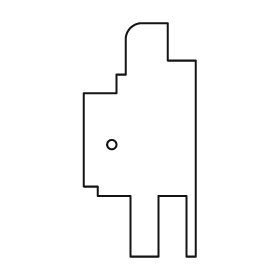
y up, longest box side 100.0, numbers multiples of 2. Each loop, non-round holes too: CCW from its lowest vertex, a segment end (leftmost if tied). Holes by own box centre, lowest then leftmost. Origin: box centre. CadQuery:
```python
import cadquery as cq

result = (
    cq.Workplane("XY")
    .moveTo(-4.0, -50.0)
    .lineTo(8.0, -50.0)
    .lineTo(8.0, -24.0)
    .lineTo(20.0, -24.0)
    .lineTo(20.0, -50.0)
    .lineTo(24.0, -50.0)
    .lineTo(24.0, 34.0)
    .lineTo(12.0, 34.0)
    .lineTo(12.0, 50.0)
    .lineTo(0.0, 50.0)
    .threePointArc((-4.0, 48.0), (-6.0, 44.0))
    .lineTo(-6.0, 28.0)
    .lineTo(-10.0, 28.0)
    .lineTo(-10.0, 20.0)
    .lineTo(-24.0, 20.0)
    .lineTo(-24.0, -20.0)
    .lineTo(-18.0, -20.0)
    .lineTo(-18.0, -24.0)
    .lineTo(-4.0, -24.0)
    .close()
    .moveTo(-12.0, -2.0)
    .circle(2.0)
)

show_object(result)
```